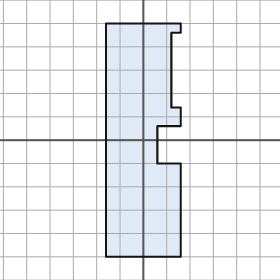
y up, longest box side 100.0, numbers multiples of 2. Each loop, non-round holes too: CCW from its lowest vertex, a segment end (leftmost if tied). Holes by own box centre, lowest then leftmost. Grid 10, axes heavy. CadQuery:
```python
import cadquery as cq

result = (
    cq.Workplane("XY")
    .moveTo(-16.0, -50.0)
    .lineTo(16.0, -50.0)
    .lineTo(16.0, -10.0)
    .lineTo(6.0, -10.0)
    .lineTo(6.0, 6.0)
    .lineTo(16.0, 6.0)
    .lineTo(16.0, 14.0)
    .lineTo(12.0, 14.0)
    .lineTo(12.0, 46.0)
    .lineTo(16.0, 46.0)
    .lineTo(16.0, 50.0)
    .lineTo(-16.0, 50.0)
    .close()
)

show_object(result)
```